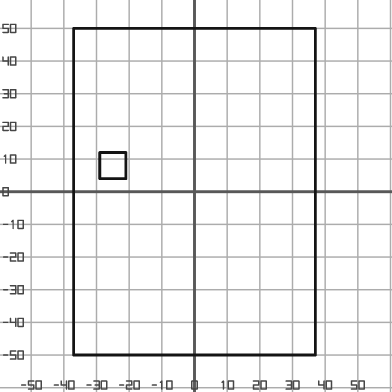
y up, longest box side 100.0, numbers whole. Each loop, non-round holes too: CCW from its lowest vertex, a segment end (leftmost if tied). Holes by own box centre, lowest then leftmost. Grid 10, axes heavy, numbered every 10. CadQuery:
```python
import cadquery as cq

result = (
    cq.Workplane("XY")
    .moveTo(-37.0, -50.0)
    .lineTo(37.0, -50.0)
    .lineTo(37.0, 50.0)
    .lineTo(-37.0, 50.0)
    .close()
    .moveTo(-29.0, 4.0)
    .lineTo(-21.0, 4.0)
    .lineTo(-21.0, 12.0)
    .lineTo(-29.0, 12.0)
    .close()
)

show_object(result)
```